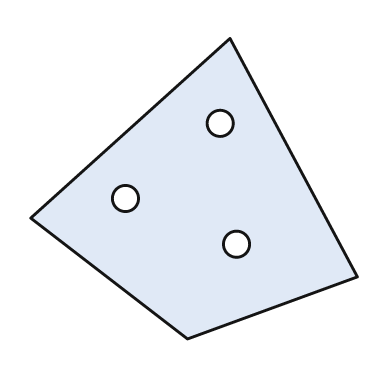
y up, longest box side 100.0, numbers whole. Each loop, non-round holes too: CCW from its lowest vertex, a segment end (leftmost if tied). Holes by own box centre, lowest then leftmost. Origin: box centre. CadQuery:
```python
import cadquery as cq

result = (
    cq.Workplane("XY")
    .moveTo(-2.0, -46.0)
    .lineTo(50.0, -27.0)
    .lineTo(11.0, 46.0)
    .lineTo(-50.0, -9.0)
    .close()
    .moveTo(13.0, -17.0)
    .circle(4.0)
    .moveTo(-21.0, -3.0)
    .circle(4.0)
    .moveTo(8.0, 20.0)
    .circle(4.0)
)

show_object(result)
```